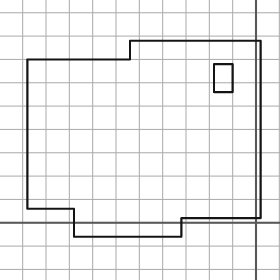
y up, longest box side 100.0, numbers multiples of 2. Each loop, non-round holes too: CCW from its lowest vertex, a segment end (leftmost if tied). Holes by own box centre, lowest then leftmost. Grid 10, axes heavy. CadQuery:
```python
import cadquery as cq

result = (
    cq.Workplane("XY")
    .moveTo(-78.0, -6.0)
    .lineTo(-32.0, -6.0)
    .lineTo(-32.0, 2.0)
    .lineTo(2.0, 2.0)
    .lineTo(2.0, 78.0)
    .lineTo(-54.0, 78.0)
    .lineTo(-54.0, 70.0)
    .lineTo(-98.0, 70.0)
    .lineTo(-98.0, 6.0)
    .lineTo(-78.0, 6.0)
    .close()
    .moveTo(-18.0, 56.0)
    .lineTo(-10.0, 56.0)
    .lineTo(-10.0, 68.0)
    .lineTo(-18.0, 68.0)
    .close()
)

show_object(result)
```